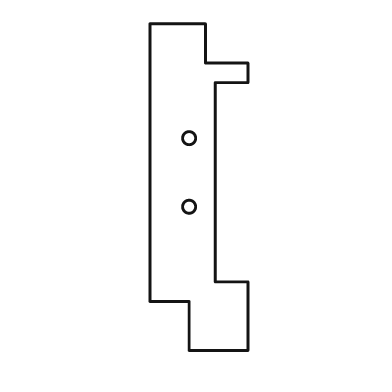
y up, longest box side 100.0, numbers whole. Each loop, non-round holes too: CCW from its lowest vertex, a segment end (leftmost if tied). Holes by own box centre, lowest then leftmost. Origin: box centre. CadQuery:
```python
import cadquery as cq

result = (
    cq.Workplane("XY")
    .moveTo(-3.0, -50.0)
    .lineTo(15.0, -50.0)
    .lineTo(15.0, -29.0)
    .lineTo(5.0, -29.0)
    .lineTo(5.0, 32.0)
    .lineTo(15.0, 32.0)
    .lineTo(15.0, 38.0)
    .lineTo(2.0, 38.0)
    .lineTo(2.0, 50.0)
    .lineTo(-15.0, 50.0)
    .lineTo(-15.0, -35.0)
    .lineTo(-3.0, -35.0)
    .close()
    .moveTo(-3.0, -6.0)
    .circle(2.0)
    .moveTo(-3.0, 15.0)
    .circle(2.0)
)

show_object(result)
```